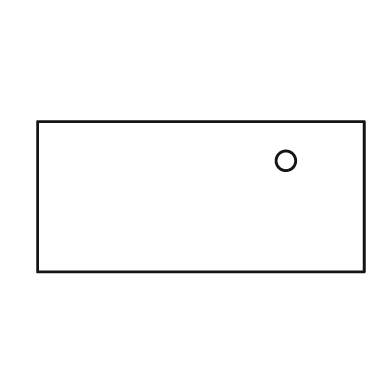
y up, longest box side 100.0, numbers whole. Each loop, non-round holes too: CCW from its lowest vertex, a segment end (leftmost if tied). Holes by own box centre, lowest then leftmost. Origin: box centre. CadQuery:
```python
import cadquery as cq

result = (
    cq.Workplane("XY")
    .moveTo(-50.0, -23.0)
    .lineTo(50.0, -23.0)
    .lineTo(50.0, 23.0)
    .lineTo(-50.0, 23.0)
    .close()
    .moveTo(26.0, 11.0)
    .circle(3.0)
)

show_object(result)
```